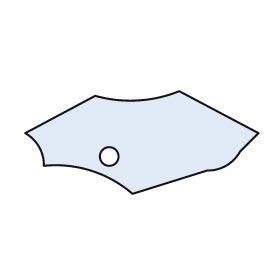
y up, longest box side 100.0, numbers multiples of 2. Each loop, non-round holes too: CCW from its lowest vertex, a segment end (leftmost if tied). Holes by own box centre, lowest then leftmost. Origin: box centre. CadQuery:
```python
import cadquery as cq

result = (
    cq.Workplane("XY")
    .moveTo(-4.0, -22.0)
    .lineTo(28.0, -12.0)
    .threePointArc((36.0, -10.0), (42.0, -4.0))
    .lineTo(50.0, 4.0)
    .lineTo(16.0, 22.0)
    .threePointArc((-2.0, 18.0), (-20.0, 20.0))
    .lineTo(-50.0, 4.0)
    .threePointArc((-44.0, -2.0), (-42.0, -10.0))
    .threePointArc((-22.0, -12.0), (-4.0, -22.0))
    .close()
    .moveTo(-14.0, -6.0)
    .circle(4.0)
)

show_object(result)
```